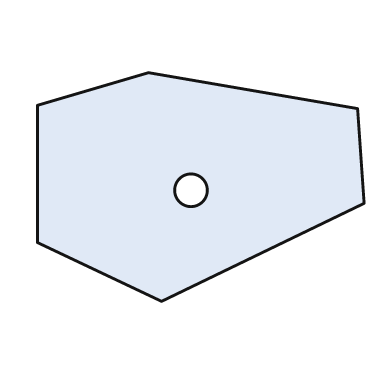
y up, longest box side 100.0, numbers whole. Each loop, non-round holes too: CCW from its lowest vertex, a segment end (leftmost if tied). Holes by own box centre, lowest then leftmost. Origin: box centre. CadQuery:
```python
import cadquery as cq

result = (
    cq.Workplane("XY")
    .moveTo(-12.0, -35.0)
    .lineTo(50.0, -5.0)
    .lineTo(48.0, 24.0)
    .lineTo(-16.0, 35.0)
    .lineTo(-50.0, 25.0)
    .lineTo(-50.0, -17.0)
    .close()
    .moveTo(-3.0, -1.0)
    .circle(5.0)
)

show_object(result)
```